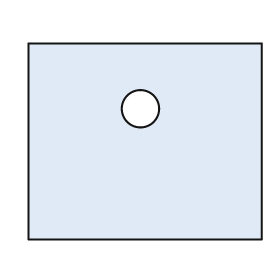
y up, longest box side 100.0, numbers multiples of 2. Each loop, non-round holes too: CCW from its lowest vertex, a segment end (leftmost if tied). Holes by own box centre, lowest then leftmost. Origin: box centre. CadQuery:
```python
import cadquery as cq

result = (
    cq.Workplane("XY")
    .moveTo(-50.0, -42.0)
    .lineTo(50.0, -42.0)
    .lineTo(50.0, 42.0)
    .lineTo(-50.0, 42.0)
    .close()
    .moveTo(-2.0, 14.0)
    .circle(8.0)
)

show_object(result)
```